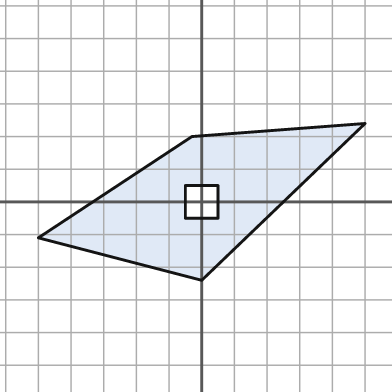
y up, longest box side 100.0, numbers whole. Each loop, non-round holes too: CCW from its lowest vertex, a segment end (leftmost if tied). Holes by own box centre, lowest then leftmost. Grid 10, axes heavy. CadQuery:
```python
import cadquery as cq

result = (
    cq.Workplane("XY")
    .moveTo(0.0, -24.0)
    .lineTo(50.0, 24.0)
    .lineTo(-3.0, 20.0)
    .lineTo(-50.0, -11.0)
    .close()
    .moveTo(-5.0, -5.0)
    .lineTo(5.0, -5.0)
    .lineTo(5.0, 5.0)
    .lineTo(-5.0, 5.0)
    .close()
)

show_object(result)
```